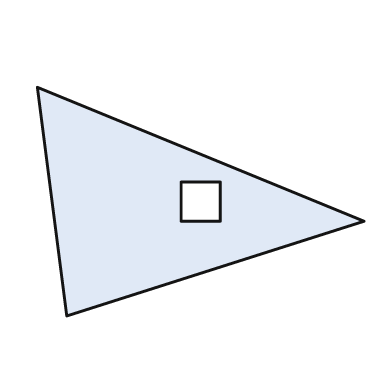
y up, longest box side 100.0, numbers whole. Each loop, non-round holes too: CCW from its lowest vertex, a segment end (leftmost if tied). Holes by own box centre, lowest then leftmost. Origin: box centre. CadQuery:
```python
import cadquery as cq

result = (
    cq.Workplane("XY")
    .moveTo(-41.0, -35.0)
    .lineTo(50.0, -6.0)
    .lineTo(-50.0, 35.0)
    .close()
    .moveTo(-6.0, -6.0)
    .lineTo(6.0, -6.0)
    .lineTo(6.0, 6.0)
    .lineTo(-6.0, 6.0)
    .close()
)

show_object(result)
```